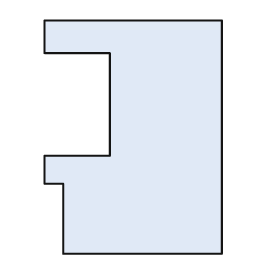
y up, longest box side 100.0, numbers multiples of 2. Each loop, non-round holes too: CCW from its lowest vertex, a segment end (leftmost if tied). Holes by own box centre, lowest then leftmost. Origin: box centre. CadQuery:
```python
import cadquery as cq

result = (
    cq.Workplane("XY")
    .moveTo(-30.0, -50.0)
    .lineTo(38.0, -50.0)
    .lineTo(38.0, 50.0)
    .lineTo(-38.0, 50.0)
    .lineTo(-38.0, 36.0)
    .lineTo(-10.0, 36.0)
    .lineTo(-10.0, -8.0)
    .lineTo(-38.0, -8.0)
    .lineTo(-38.0, -20.0)
    .lineTo(-30.0, -20.0)
    .close()
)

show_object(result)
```